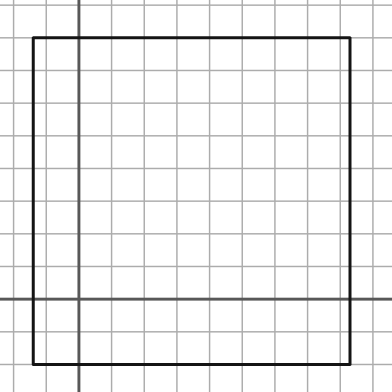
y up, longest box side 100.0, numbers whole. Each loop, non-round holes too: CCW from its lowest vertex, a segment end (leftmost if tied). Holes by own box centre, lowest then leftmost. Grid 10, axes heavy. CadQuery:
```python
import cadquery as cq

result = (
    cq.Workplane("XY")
    .moveTo(-14.0, -20.0)
    .lineTo(83.0, -20.0)
    .lineTo(83.0, 80.0)
    .lineTo(-14.0, 80.0)
    .close()
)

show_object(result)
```